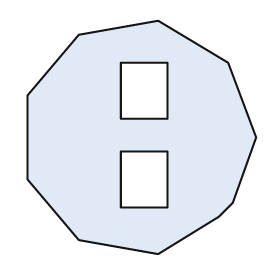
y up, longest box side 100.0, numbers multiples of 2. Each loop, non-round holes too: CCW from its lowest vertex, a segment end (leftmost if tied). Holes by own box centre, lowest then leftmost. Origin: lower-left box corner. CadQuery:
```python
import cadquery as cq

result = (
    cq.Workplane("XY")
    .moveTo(56.0, 0.0)
    .lineTo(82.0, 16.0)
    .lineTo(88.0, 22.0)
    .lineTo(98.0, 50.0)
    .lineTo(86.0, 82.0)
    .lineTo(56.0, 100.0)
    .lineTo(22.0, 94.0)
    .lineTo(0.0, 68.0)
    .lineTo(0.0, 32.0)
    .lineTo(22.0, 6.0)
    .close()
    .moveTo(40.0, 20.0)
    .lineTo(60.0, 20.0)
    .lineTo(60.0, 44.0)
    .lineTo(40.0, 44.0)
    .close()
    .moveTo(40.0, 58.0)
    .lineTo(60.0, 58.0)
    .lineTo(60.0, 82.0)
    .lineTo(40.0, 82.0)
    .close()
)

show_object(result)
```